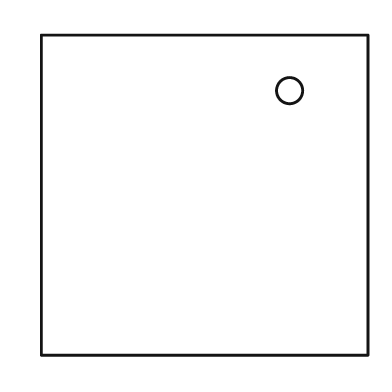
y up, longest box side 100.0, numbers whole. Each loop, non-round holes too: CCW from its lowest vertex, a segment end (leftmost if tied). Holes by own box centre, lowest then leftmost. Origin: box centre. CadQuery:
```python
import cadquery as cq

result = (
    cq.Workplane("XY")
    .moveTo(-50.0, -49.0)
    .lineTo(50.0, -49.0)
    .lineTo(50.0, 49.0)
    .lineTo(-50.0, 49.0)
    .close()
    .moveTo(26.0, 32.0)
    .circle(4.0)
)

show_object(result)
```